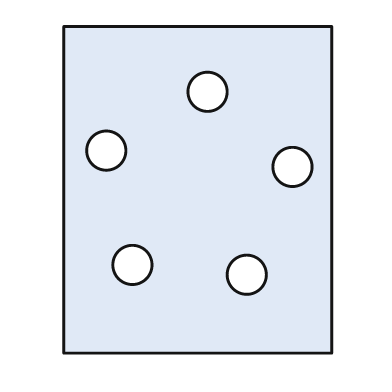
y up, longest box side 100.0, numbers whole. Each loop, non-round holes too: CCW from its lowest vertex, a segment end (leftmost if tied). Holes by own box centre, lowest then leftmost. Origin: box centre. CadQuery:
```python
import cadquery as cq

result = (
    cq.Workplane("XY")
    .moveTo(-41.0, -50.0)
    .lineTo(41.0, -50.0)
    .lineTo(41.0, 50.0)
    .lineTo(-41.0, 50.0)
    .close()
    .moveTo(15.0, -26.0)
    .circle(6.0)
    .moveTo(-20.0, -23.0)
    .circle(6.0)
    .moveTo(29.0, 7.0)
    .circle(6.0)
    .moveTo(-28.0, 12.0)
    .circle(6.0)
    .moveTo(3.0, 30.0)
    .circle(6.0)
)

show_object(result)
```